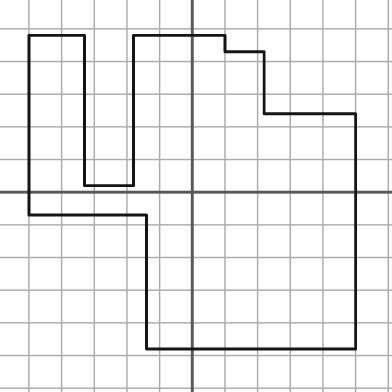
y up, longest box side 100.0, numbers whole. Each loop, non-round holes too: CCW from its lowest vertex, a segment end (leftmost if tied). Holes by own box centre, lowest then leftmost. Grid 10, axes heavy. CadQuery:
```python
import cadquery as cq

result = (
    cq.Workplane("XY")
    .moveTo(-14.0, -48.0)
    .lineTo(50.0, -48.0)
    .lineTo(50.0, 24.0)
    .lineTo(22.0, 24.0)
    .lineTo(22.0, 43.0)
    .lineTo(10.0, 43.0)
    .lineTo(10.0, 48.0)
    .lineTo(-18.0, 48.0)
    .lineTo(-18.0, 2.0)
    .lineTo(-33.0, 2.0)
    .lineTo(-33.0, 48.0)
    .lineTo(-50.0, 48.0)
    .lineTo(-50.0, -7.0)
    .lineTo(-14.0, -7.0)
    .close()
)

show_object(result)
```